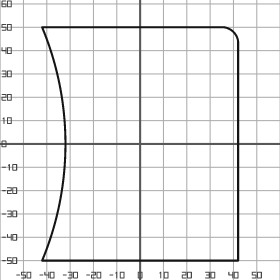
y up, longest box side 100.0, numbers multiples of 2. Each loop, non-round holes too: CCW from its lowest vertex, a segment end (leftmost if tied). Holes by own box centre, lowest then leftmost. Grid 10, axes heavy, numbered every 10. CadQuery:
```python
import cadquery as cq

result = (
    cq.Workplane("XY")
    .moveTo(-42.0, -50.0)
    .lineTo(42.0, -50.0)
    .lineTo(42.0, 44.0)
    .threePointArc((40.0, 48.0), (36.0, 50.0))
    .lineTo(-42.0, 50.0)
    .threePointArc((-32.0, 0.0), (-42.0, -50.0))
    .close()
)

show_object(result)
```